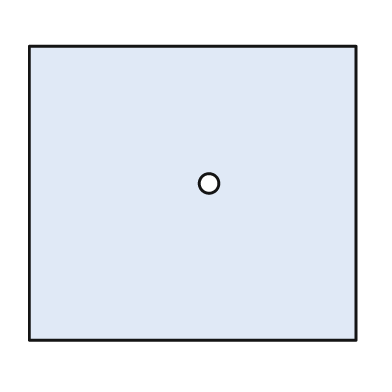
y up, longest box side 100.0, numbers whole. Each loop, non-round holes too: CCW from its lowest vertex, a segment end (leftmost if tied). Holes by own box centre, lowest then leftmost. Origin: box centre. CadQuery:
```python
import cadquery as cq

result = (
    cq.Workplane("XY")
    .moveTo(-50.0, -45.0)
    .lineTo(50.0, -45.0)
    .lineTo(50.0, 45.0)
    .lineTo(-50.0, 45.0)
    .close()
    .moveTo(5.0, 3.0)
    .circle(3.0)
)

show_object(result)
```